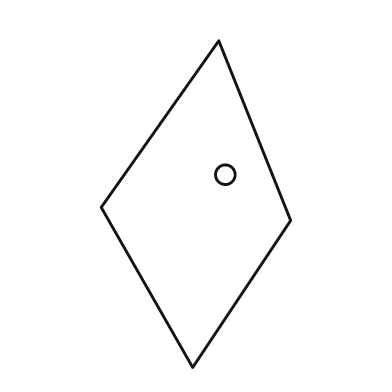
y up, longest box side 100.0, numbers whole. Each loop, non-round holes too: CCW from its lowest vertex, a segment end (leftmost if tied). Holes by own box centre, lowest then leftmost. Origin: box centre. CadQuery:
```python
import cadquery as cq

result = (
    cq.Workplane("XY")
    .moveTo(-1.0, -50.0)
    .lineTo(29.0, -5.0)
    .lineTo(7.0, 50.0)
    .lineTo(-29.0, -1.0)
    .close()
    .moveTo(9.0, 9.0)
    .circle(3.0)
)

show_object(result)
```